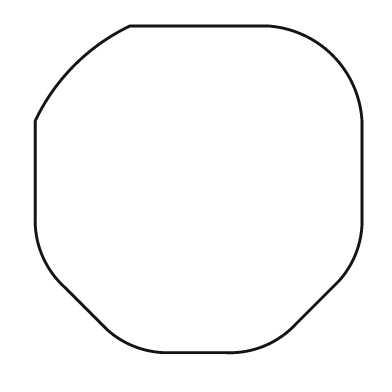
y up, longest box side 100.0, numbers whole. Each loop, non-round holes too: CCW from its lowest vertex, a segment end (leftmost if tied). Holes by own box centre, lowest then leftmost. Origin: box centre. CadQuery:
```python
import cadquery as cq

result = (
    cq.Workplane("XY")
    .moveTo(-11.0, -50.0)
    .lineTo(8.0, -50.0)
    .threePointArc((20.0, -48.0), (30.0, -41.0))
    .lineTo(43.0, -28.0)
    .threePointArc((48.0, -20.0), (50.0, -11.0))
    .lineTo(50.0, 21.0)
    .threePointArc((41.0, 41.0), (21.0, 50.0))
    .lineTo(-21.0, 50.0)
    .threePointArc((-38.0, 38.0), (-50.0, 21.0))
    .lineTo(-50.0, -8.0)
    .threePointArc((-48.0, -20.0), (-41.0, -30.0))
    .lineTo(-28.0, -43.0)
    .threePointArc((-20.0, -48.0), (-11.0, -50.0))
    .close()
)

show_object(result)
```